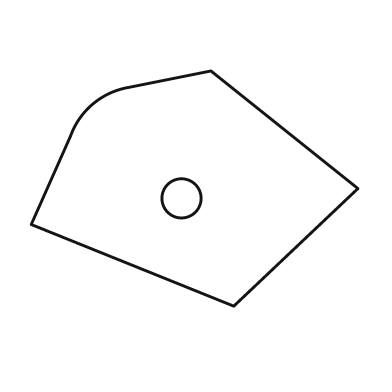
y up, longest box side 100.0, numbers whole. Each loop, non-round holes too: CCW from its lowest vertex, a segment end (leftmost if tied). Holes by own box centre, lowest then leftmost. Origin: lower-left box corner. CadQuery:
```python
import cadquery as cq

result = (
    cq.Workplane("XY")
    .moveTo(62.0, 0.0)
    .lineTo(100.0, 36.0)
    .lineTo(55.0, 72.0)
    .lineTo(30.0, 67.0)
    .threePointArc((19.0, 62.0), (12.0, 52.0))
    .lineTo(0.0, 25.0)
    .close()
    .moveTo(46.0, 33.0)
    .circle(6.0)
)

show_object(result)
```